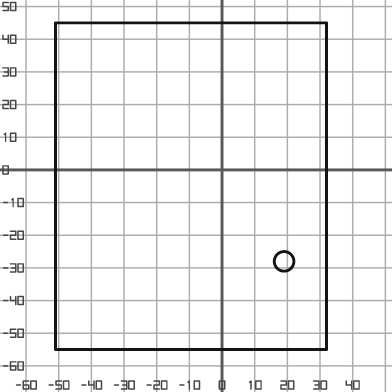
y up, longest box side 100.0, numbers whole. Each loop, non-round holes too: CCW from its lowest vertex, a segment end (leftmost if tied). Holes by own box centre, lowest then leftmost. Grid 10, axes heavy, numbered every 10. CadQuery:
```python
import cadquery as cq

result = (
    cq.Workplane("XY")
    .moveTo(-51.0, -55.0)
    .lineTo(32.0, -55.0)
    .lineTo(32.0, 45.0)
    .lineTo(-51.0, 45.0)
    .close()
    .moveTo(19.0, -28.0)
    .circle(3.0)
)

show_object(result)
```